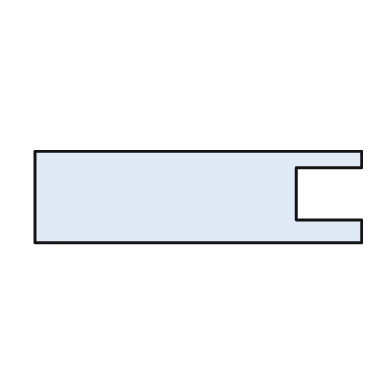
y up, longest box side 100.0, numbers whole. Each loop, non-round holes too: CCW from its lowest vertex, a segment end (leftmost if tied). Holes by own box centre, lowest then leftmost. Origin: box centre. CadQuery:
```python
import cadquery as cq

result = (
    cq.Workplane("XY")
    .moveTo(-50.0, -14.0)
    .lineTo(50.0, -14.0)
    .lineTo(50.0, -7.0)
    .lineTo(30.0, -7.0)
    .lineTo(30.0, 9.0)
    .lineTo(50.0, 9.0)
    .lineTo(50.0, 14.0)
    .lineTo(-50.0, 14.0)
    .close()
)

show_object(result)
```